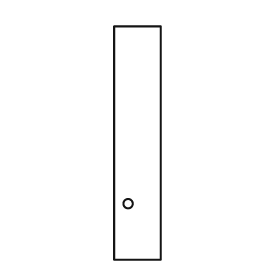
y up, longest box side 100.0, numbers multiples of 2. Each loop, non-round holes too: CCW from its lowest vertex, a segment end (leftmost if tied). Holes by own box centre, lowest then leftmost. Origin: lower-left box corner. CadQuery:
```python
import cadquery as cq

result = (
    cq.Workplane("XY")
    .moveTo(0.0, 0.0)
    .lineTo(20.0, 0.0)
    .lineTo(20.0, 100.0)
    .lineTo(0.0, 100.0)
    .close()
    .moveTo(6.0, 24.0)
    .circle(2.0)
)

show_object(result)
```